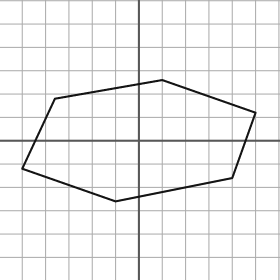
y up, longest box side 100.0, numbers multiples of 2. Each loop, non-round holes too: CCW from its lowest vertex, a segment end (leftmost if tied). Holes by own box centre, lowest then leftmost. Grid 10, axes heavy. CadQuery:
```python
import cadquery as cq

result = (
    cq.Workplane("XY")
    .moveTo(-10.0, -26.0)
    .lineTo(40.0, -16.0)
    .lineTo(50.0, 12.0)
    .lineTo(10.0, 26.0)
    .lineTo(-36.0, 18.0)
    .lineTo(-50.0, -12.0)
    .close()
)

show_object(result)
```